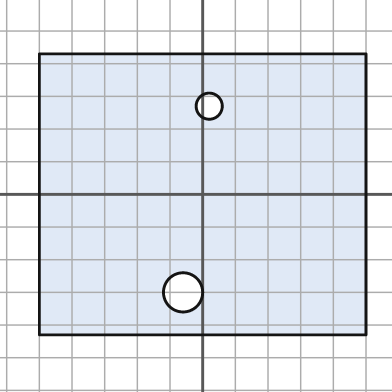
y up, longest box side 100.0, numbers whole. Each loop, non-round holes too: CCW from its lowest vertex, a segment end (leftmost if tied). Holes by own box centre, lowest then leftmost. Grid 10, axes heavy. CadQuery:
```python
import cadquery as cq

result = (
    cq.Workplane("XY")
    .moveTo(-50.0, -43.0)
    .lineTo(50.0, -43.0)
    .lineTo(50.0, 43.0)
    .lineTo(-50.0, 43.0)
    .close()
    .moveTo(-6.0, -30.0)
    .circle(6.0)
    .moveTo(2.0, 27.0)
    .circle(4.0)
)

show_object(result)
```